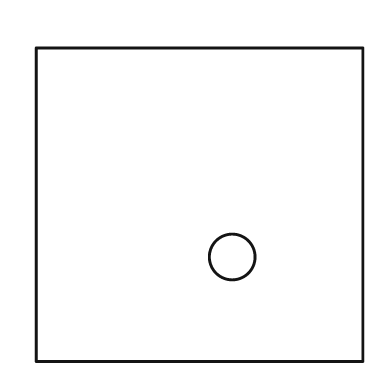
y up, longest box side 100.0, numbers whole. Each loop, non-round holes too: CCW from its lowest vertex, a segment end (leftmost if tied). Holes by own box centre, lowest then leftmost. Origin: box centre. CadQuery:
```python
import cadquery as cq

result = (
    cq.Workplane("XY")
    .moveTo(-50.0, -48.0)
    .lineTo(50.0, -48.0)
    .lineTo(50.0, 48.0)
    .lineTo(-50.0, 48.0)
    .close()
    .moveTo(10.0, -16.0)
    .circle(7.0)
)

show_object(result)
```